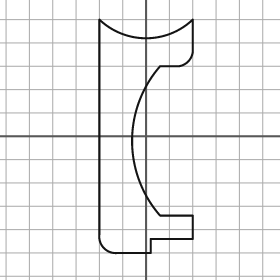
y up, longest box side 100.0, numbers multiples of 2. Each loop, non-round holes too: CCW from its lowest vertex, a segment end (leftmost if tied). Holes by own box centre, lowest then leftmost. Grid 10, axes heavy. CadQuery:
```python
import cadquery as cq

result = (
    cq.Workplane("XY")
    .moveTo(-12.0, -50.0)
    .lineTo(2.0, -50.0)
    .lineTo(2.0, -44.0)
    .lineTo(20.0, -44.0)
    .lineTo(20.0, -34.0)
    .lineTo(6.0, -34.0)
    .threePointArc((-6.0, -2.0), (6.0, 30.0))
    .lineTo(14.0, 30.0)
    .threePointArc((18.0, 32.0), (20.0, 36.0))
    .lineTo(20.0, 50.0)
    .threePointArc((0.0, 42.0), (-20.0, 50.0))
    .lineTo(-20.0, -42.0)
    .threePointArc((-18.0, -48.0), (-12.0, -50.0))
    .close()
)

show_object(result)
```